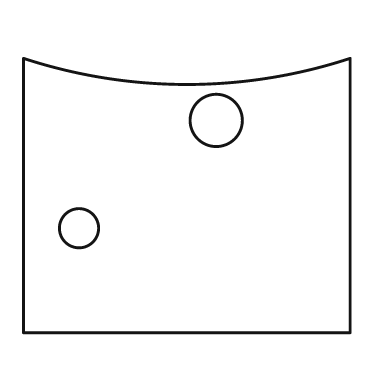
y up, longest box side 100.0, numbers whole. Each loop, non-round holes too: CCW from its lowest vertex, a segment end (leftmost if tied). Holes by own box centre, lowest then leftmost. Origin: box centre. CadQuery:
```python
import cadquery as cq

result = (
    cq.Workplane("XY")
    .moveTo(-50.0, -42.0)
    .lineTo(50.0, -42.0)
    .lineTo(50.0, 42.0)
    .threePointArc((0.0, 34.0), (-50.0, 42.0))
    .close()
    .moveTo(-33.0, -10.0)
    .circle(6.0)
    .moveTo(9.0, 23.0)
    .circle(8.0)
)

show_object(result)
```